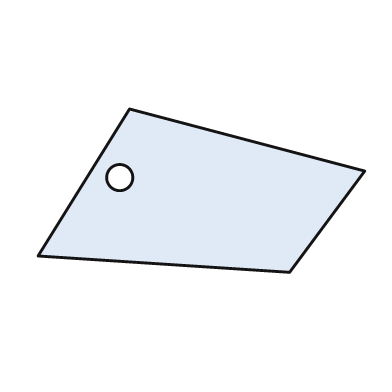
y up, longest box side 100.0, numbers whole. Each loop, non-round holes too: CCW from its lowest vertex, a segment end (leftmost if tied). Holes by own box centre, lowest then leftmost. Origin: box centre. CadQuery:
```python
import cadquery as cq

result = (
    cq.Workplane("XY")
    .moveTo(27.0, -25.0)
    .lineTo(50.0, 6.0)
    .lineTo(-22.0, 25.0)
    .lineTo(-50.0, -20.0)
    .close()
    .moveTo(-25.0, 4.0)
    .circle(4.0)
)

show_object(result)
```